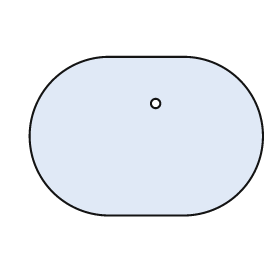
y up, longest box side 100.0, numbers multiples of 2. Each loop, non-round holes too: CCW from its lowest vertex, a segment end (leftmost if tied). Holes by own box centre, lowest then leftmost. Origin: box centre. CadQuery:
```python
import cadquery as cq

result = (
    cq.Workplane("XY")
    .moveTo(-16.0, -34.0)
    .lineTo(16.0, -34.0)
    .threePointArc((50.0, 0.0), (16.0, 34.0))
    .lineTo(-16.0, 34.0)
    .threePointArc((-50.0, 0.0), (-16.0, -34.0))
    .close()
    .moveTo(4.0, 14.0)
    .circle(2.0)
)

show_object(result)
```